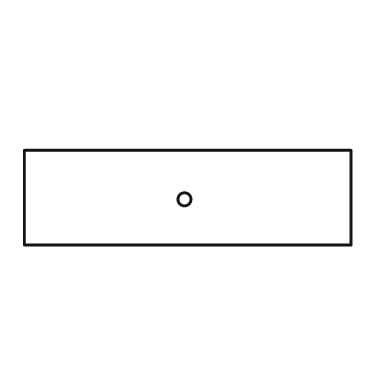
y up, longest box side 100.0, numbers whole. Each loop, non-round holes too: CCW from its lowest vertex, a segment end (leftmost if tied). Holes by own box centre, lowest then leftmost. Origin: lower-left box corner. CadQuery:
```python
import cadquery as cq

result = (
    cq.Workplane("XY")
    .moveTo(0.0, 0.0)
    .lineTo(100.0, 0.0)
    .lineTo(100.0, 29.0)
    .lineTo(0.0, 29.0)
    .close()
    .moveTo(49.0, 14.0)
    .circle(2.0)
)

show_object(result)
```